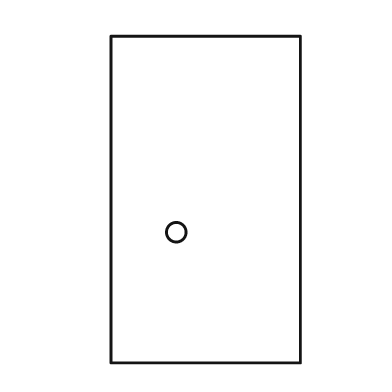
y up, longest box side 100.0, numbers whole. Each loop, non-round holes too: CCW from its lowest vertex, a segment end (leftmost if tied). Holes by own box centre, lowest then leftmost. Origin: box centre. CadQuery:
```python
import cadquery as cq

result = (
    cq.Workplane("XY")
    .moveTo(-29.0, -50.0)
    .lineTo(29.0, -50.0)
    .lineTo(29.0, 50.0)
    .lineTo(-29.0, 50.0)
    .close()
    .moveTo(-9.0, -10.0)
    .circle(3.0)
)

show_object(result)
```